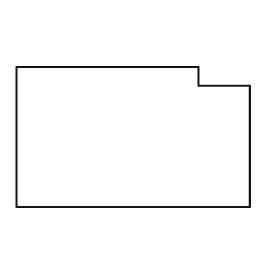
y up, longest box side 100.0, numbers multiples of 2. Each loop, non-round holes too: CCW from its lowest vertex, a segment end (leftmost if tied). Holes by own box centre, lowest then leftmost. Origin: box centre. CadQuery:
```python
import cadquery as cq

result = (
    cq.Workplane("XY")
    .moveTo(-50.0, -30.0)
    .lineTo(50.0, -30.0)
    .lineTo(50.0, 22.0)
    .lineTo(28.0, 22.0)
    .lineTo(28.0, 30.0)
    .lineTo(-50.0, 30.0)
    .close()
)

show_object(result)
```